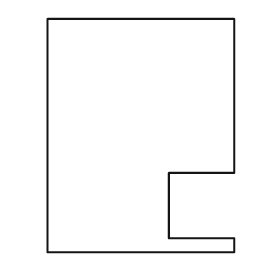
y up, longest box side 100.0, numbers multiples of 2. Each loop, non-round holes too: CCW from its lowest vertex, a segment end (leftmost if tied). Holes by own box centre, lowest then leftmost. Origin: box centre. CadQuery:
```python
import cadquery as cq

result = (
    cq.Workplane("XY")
    .moveTo(-40.0, -50.0)
    .lineTo(40.0, -50.0)
    .lineTo(40.0, -44.0)
    .lineTo(12.0, -44.0)
    .lineTo(12.0, -16.0)
    .lineTo(40.0, -16.0)
    .lineTo(40.0, 50.0)
    .lineTo(-40.0, 50.0)
    .close()
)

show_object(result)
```